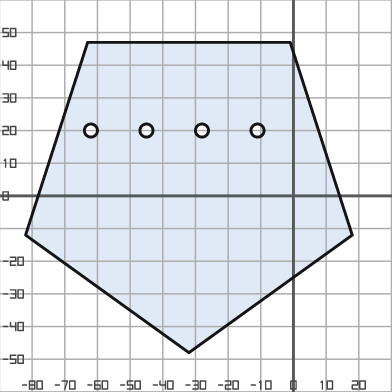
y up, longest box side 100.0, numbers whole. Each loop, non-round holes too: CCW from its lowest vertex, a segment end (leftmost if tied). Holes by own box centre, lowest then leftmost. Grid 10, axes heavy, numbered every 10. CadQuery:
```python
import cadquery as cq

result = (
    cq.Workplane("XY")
    .moveTo(-32.0, -48.0)
    .lineTo(18.0, -12.0)
    .lineTo(-1.0, 47.0)
    .lineTo(-63.0, 47.0)
    .lineTo(-82.0, -12.0)
    .close()
    .moveTo(-62.0, 20.0)
    .circle(2.0)
    .moveTo(-45.0, 20.0)
    .circle(2.0)
    .moveTo(-28.0, 20.0)
    .circle(2.0)
    .moveTo(-11.0, 20.0)
    .circle(2.0)
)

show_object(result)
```